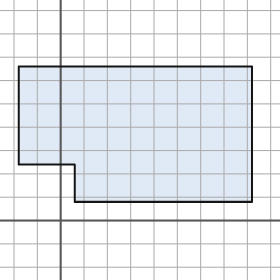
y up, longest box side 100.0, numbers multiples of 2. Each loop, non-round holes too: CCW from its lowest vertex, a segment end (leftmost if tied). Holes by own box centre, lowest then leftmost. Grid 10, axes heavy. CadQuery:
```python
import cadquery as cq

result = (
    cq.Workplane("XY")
    .moveTo(6.0, 8.0)
    .lineTo(82.0, 8.0)
    .lineTo(82.0, 66.0)
    .lineTo(-18.0, 66.0)
    .lineTo(-18.0, 24.0)
    .lineTo(6.0, 24.0)
    .close()
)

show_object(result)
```